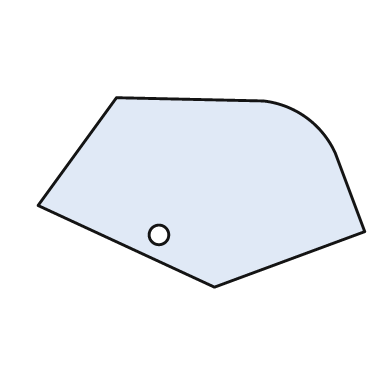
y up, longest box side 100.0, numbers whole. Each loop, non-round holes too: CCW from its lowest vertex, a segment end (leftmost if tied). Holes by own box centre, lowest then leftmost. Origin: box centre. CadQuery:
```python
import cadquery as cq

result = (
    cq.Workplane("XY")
    .moveTo(4.0, -29.0)
    .lineTo(50.0, -12.0)
    .lineTo(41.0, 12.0)
    .threePointArc((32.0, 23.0), (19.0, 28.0))
    .lineTo(-26.0, 29.0)
    .lineTo(-50.0, -4.0)
    .close()
    .moveTo(-13.0, -13.0)
    .circle(3.0)
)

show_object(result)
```